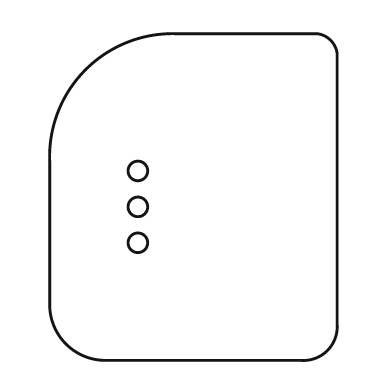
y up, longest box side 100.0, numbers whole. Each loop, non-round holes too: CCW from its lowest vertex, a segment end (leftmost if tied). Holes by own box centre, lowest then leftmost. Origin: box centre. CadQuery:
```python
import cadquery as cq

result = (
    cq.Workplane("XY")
    .moveTo(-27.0, -50.0)
    .lineTo(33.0, -50.0)
    .threePointArc((41.0, -47.0), (44.0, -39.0))
    .lineTo(44.0, 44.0)
    .threePointArc((42.0, 48.0), (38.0, 50.0))
    .lineTo(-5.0, 50.0)
    .threePointArc((-33.0, 39.0), (-44.0, 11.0))
    .lineTo(-44.0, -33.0)
    .threePointArc((-39.0, -45.0), (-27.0, -50.0))
    .close()
    .moveTo(-17.0, -14.0)
    .circle(3.0)
    .moveTo(-17.0, -3.0)
    .circle(3.0)
    .moveTo(-17.0, 8.0)
    .circle(3.0)
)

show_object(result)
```